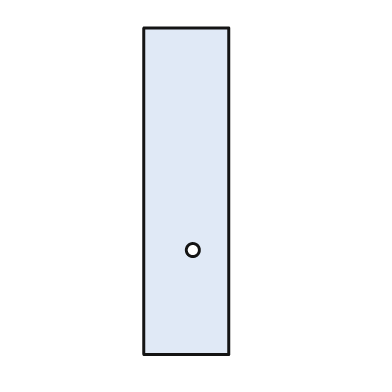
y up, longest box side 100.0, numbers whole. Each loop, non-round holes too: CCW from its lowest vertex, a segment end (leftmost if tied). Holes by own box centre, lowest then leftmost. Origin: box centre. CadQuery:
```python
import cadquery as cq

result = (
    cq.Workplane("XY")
    .moveTo(-13.0, -50.0)
    .lineTo(13.0, -50.0)
    .lineTo(13.0, 50.0)
    .lineTo(-13.0, 50.0)
    .close()
    .moveTo(2.0, -18.0)
    .circle(2.0)
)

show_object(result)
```